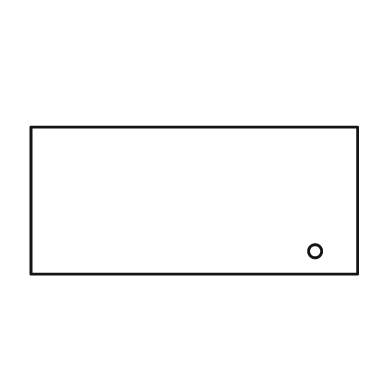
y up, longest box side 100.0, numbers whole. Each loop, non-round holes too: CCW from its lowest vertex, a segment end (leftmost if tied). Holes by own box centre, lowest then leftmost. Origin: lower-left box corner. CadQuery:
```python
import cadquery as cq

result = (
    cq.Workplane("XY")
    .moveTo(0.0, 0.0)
    .lineTo(100.0, 0.0)
    .lineTo(100.0, 45.0)
    .lineTo(0.0, 45.0)
    .close()
    .moveTo(87.0, 7.0)
    .circle(2.0)
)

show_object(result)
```